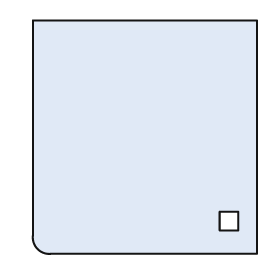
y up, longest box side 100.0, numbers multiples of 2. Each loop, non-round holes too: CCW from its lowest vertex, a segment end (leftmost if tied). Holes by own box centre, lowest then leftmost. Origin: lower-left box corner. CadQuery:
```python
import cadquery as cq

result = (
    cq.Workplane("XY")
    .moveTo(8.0, 0.0)
    .lineTo(96.0, 0.0)
    .lineTo(96.0, 100.0)
    .lineTo(0.0, 100.0)
    .lineTo(0.0, 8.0)
    .threePointArc((2.0, 2.0), (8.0, 0.0))
    .close()
    .moveTo(80.0, 10.0)
    .lineTo(88.0, 10.0)
    .lineTo(88.0, 18.0)
    .lineTo(80.0, 18.0)
    .close()
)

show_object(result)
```